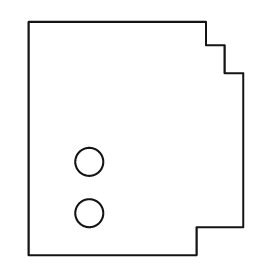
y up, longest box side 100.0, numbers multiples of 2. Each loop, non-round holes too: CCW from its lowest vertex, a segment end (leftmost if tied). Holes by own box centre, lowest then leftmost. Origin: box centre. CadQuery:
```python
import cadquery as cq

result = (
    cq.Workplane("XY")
    .moveTo(-46.0, -50.0)
    .lineTo(26.0, -50.0)
    .lineTo(26.0, -38.0)
    .lineTo(46.0, -38.0)
    .lineTo(46.0, 28.0)
    .lineTo(38.0, 28.0)
    .lineTo(38.0, 40.0)
    .lineTo(30.0, 40.0)
    .lineTo(30.0, 50.0)
    .lineTo(-46.0, 50.0)
    .close()
    .moveTo(-20.0, -32.0)
    .circle(6.0)
    .moveTo(-20.0, -10.0)
    .circle(6.0)
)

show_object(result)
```